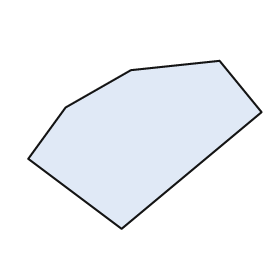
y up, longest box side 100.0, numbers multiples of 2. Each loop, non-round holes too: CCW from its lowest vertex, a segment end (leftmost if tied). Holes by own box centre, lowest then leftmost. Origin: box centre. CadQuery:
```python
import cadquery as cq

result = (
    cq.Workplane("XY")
    .moveTo(-10.0, -36.0)
    .lineTo(50.0, 14.0)
    .lineTo(32.0, 36.0)
    .lineTo(-6.0, 32.0)
    .lineTo(-34.0, 16.0)
    .lineTo(-50.0, -6.0)
    .close()
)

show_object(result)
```